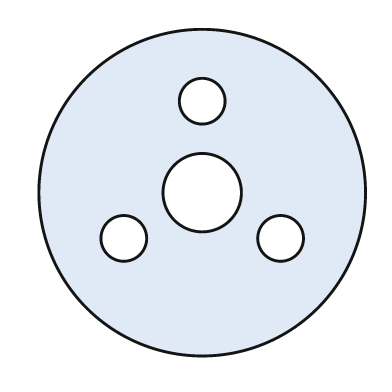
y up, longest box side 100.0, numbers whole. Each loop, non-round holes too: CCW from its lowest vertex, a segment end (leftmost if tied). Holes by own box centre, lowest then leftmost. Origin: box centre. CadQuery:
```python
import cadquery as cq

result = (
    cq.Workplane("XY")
    .moveTo(0.0, 0.0)
    .circle(50.0)
    .moveTo(-24.0, -14.0)
    .circle(7.0)
    .moveTo(24.0, -14.0)
    .circle(7.0)
    .moveTo(0.0, 0.0)
    .circle(12.0)
    .moveTo(0.0, 28.0)
    .circle(7.0)
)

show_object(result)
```